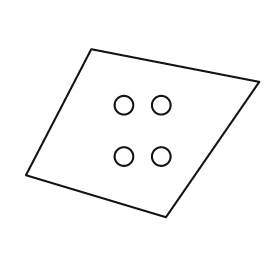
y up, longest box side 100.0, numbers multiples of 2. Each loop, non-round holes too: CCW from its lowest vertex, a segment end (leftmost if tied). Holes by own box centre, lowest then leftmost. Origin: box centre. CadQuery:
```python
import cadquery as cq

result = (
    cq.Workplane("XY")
    .moveTo(10.0, -36.0)
    .lineTo(50.0, 22.0)
    .lineTo(-22.0, 36.0)
    .lineTo(-50.0, -18.0)
    .close()
    .moveTo(-8.0, -10.0)
    .circle(4.0)
    .moveTo(8.0, -10.0)
    .circle(4.0)
    .moveTo(-8.0, 12.0)
    .circle(4.0)
    .moveTo(8.0, 12.0)
    .circle(4.0)
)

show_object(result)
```